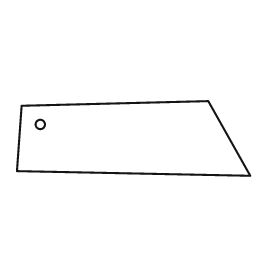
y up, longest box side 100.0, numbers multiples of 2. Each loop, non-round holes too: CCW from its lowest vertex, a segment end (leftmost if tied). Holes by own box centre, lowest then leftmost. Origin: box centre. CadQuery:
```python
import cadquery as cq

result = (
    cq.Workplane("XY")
    .moveTo(50.0, -16.0)
    .lineTo(32.0, 16.0)
    .lineTo(-48.0, 14.0)
    .lineTo(-50.0, -14.0)
    .close()
    .moveTo(-40.0, 6.0)
    .circle(2.0)
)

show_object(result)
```